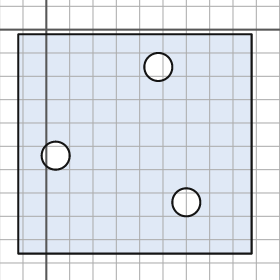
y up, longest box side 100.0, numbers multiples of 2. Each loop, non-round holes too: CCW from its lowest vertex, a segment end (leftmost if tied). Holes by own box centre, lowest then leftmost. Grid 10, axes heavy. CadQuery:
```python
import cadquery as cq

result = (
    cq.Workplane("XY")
    .moveTo(-12.0, -96.0)
    .lineTo(88.0, -96.0)
    .lineTo(88.0, -2.0)
    .lineTo(-12.0, -2.0)
    .close()
    .moveTo(60.0, -74.0)
    .circle(6.0)
    .moveTo(4.0, -54.0)
    .circle(6.0)
    .moveTo(48.0, -16.0)
    .circle(6.0)
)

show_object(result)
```